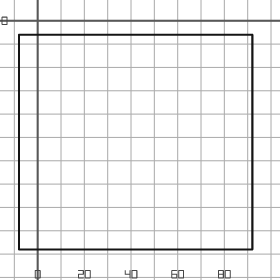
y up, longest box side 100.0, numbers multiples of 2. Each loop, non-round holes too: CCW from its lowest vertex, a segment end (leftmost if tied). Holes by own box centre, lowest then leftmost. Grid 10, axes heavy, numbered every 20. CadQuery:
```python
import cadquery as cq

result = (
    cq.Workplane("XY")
    .moveTo(-8.0, -98.0)
    .lineTo(92.0, -98.0)
    .lineTo(92.0, -6.0)
    .lineTo(-8.0, -6.0)
    .close()
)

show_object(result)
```